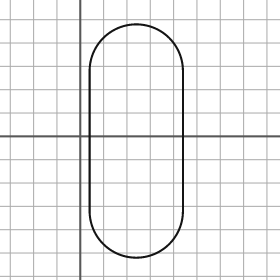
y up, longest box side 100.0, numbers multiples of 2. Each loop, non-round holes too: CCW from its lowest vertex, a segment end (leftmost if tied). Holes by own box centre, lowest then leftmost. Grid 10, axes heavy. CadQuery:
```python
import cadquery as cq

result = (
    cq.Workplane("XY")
    .moveTo(4.0, -32.0)
    .threePointArc((24.0, -52.0), (44.0, -32.0))
    .lineTo(44.0, 28.0)
    .threePointArc((24.0, 48.0), (4.0, 28.0))
    .close()
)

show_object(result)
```